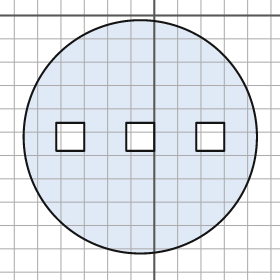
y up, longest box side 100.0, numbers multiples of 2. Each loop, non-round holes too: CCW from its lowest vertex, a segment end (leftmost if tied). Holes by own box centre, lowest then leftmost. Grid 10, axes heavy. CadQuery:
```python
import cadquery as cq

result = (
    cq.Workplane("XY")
    .moveTo(-6.0, -52.0)
    .circle(50.0)
    .moveTo(-42.0, -58.0)
    .lineTo(-30.0, -58.0)
    .lineTo(-30.0, -46.0)
    .lineTo(-42.0, -46.0)
    .close()
    .moveTo(-12.0, -58.0)
    .lineTo(0.0, -58.0)
    .lineTo(0.0, -46.0)
    .lineTo(-12.0, -46.0)
    .close()
    .moveTo(18.0, -58.0)
    .lineTo(30.0, -58.0)
    .lineTo(30.0, -46.0)
    .lineTo(18.0, -46.0)
    .close()
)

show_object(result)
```